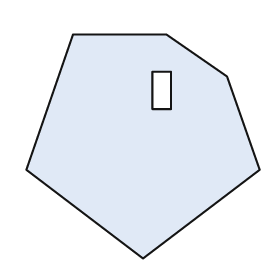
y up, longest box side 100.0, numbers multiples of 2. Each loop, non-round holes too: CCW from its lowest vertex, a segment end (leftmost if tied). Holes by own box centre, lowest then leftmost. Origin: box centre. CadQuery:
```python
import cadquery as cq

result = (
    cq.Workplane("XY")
    .moveTo(0.0, -48.0)
    .lineTo(50.0, -10.0)
    .lineTo(36.0, 30.0)
    .lineTo(10.0, 48.0)
    .lineTo(-30.0, 48.0)
    .lineTo(-50.0, -10.0)
    .close()
    .moveTo(4.0, 16.0)
    .lineTo(12.0, 16.0)
    .lineTo(12.0, 32.0)
    .lineTo(4.0, 32.0)
    .close()
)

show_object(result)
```